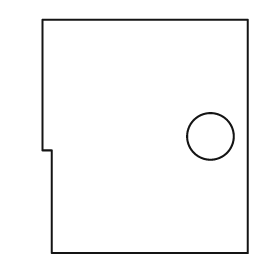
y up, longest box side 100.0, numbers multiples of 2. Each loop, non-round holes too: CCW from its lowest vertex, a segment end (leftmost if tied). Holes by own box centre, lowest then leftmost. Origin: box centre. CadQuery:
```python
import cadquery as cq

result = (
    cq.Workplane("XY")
    .moveTo(-40.0, -50.0)
    .lineTo(44.0, -50.0)
    .lineTo(44.0, 50.0)
    .lineTo(-44.0, 50.0)
    .lineTo(-44.0, -6.0)
    .lineTo(-40.0, -6.0)
    .close()
    .moveTo(28.0, 0.0)
    .circle(10.0)
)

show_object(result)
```